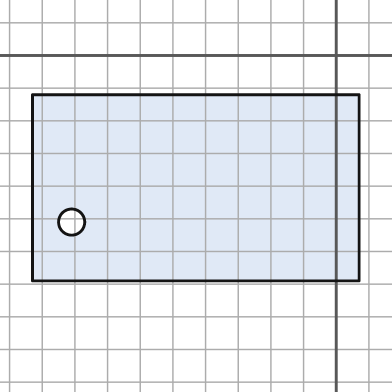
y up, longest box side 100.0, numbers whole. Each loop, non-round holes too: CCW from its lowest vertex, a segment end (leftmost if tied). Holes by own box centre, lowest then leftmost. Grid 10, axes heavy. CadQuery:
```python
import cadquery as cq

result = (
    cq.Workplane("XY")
    .moveTo(-93.0, -69.0)
    .lineTo(7.0, -69.0)
    .lineTo(7.0, -12.0)
    .lineTo(-93.0, -12.0)
    .close()
    .moveTo(-81.0, -51.0)
    .circle(4.0)
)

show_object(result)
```